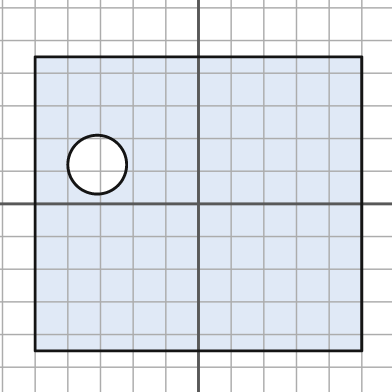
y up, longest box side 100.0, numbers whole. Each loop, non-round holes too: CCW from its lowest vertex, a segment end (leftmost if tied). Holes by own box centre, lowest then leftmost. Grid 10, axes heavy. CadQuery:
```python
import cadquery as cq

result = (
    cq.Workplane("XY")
    .moveTo(-50.0, -45.0)
    .lineTo(50.0, -45.0)
    .lineTo(50.0, 45.0)
    .lineTo(-50.0, 45.0)
    .close()
    .moveTo(-31.0, 12.0)
    .circle(9.0)
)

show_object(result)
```